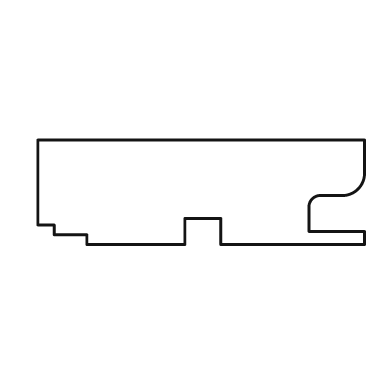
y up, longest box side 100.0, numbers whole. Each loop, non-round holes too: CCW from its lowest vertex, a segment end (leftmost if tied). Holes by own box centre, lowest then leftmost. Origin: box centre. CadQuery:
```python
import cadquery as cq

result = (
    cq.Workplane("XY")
    .moveTo(-35.0, -16.0)
    .lineTo(-5.0, -16.0)
    .lineTo(-5.0, -8.0)
    .lineTo(6.0, -8.0)
    .lineTo(6.0, -16.0)
    .lineTo(50.0, -16.0)
    .lineTo(50.0, -12.0)
    .lineTo(33.0, -12.0)
    .lineTo(33.0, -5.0)
    .threePointArc((34.0, -2.0), (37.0, -1.0))
    .lineTo(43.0, -1.0)
    .threePointArc((48.0, 1.0), (50.0, 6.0))
    .lineTo(50.0, 16.0)
    .lineTo(-50.0, 16.0)
    .lineTo(-50.0, -10.0)
    .lineTo(-45.0, -10.0)
    .lineTo(-45.0, -13.0)
    .lineTo(-35.0, -13.0)
    .close()
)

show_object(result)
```